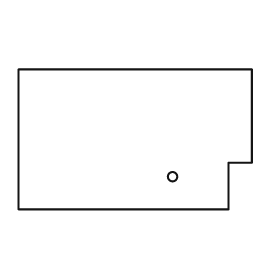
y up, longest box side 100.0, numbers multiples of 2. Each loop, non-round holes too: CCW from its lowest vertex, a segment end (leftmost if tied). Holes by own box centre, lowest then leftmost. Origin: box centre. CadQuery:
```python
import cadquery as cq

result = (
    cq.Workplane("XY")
    .moveTo(-50.0, -30.0)
    .lineTo(40.0, -30.0)
    .lineTo(40.0, -10.0)
    .lineTo(50.0, -10.0)
    .lineTo(50.0, 30.0)
    .lineTo(-50.0, 30.0)
    .close()
    .moveTo(16.0, -16.0)
    .circle(2.0)
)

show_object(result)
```